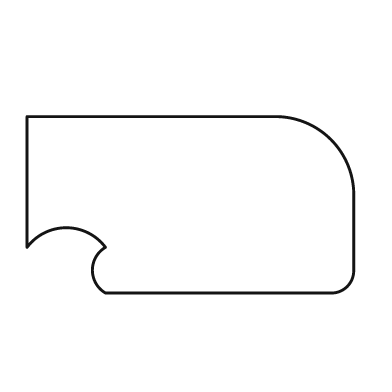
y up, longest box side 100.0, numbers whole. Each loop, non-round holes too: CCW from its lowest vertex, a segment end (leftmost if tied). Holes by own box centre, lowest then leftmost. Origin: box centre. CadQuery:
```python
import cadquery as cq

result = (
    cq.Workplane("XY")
    .moveTo(-26.0, -27.0)
    .lineTo(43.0, -27.0)
    .threePointArc((48.0, -25.0), (50.0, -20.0))
    .lineTo(50.0, 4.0)
    .threePointArc((43.0, 20.0), (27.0, 27.0))
    .lineTo(-50.0, 27.0)
    .lineTo(-50.0, -13.0)
    .threePointArc((-38.0, -7.0), (-26.0, -13.0))
    .threePointArc((-30.0, -20.0), (-26.0, -27.0))
    .close()
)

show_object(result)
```